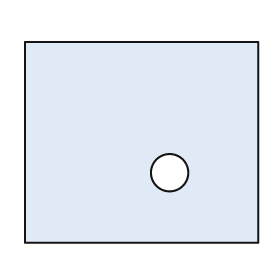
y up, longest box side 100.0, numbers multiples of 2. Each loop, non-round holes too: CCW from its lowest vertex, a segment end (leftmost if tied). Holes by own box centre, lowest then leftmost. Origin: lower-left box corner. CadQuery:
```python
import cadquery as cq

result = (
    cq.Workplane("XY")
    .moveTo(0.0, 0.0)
    .lineTo(100.0, 0.0)
    .lineTo(100.0, 86.0)
    .lineTo(0.0, 86.0)
    .close()
    .moveTo(62.0, 30.0)
    .circle(8.0)
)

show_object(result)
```